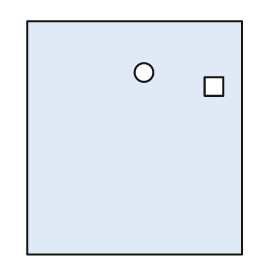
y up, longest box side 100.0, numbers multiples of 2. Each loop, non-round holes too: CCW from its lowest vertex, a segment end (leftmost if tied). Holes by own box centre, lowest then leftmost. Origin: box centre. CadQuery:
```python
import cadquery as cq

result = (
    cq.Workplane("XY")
    .moveTo(-46.0, -50.0)
    .lineTo(46.0, -50.0)
    .lineTo(46.0, 50.0)
    .lineTo(-46.0, 50.0)
    .close()
    .moveTo(30.0, 18.0)
    .lineTo(38.0, 18.0)
    .lineTo(38.0, 26.0)
    .lineTo(30.0, 26.0)
    .close()
    .moveTo(4.0, 28.0)
    .circle(4.0)
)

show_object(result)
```